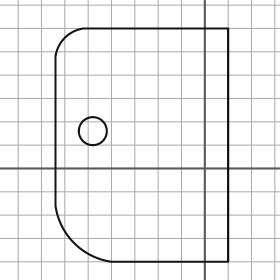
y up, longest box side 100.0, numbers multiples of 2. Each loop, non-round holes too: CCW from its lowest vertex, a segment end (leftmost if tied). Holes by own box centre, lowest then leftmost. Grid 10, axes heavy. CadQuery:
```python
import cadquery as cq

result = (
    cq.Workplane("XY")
    .moveTo(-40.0, -40.0)
    .lineTo(10.0, -40.0)
    .lineTo(10.0, 60.0)
    .lineTo(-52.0, 60.0)
    .threePointArc((-60.0, 56.0), (-64.0, 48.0))
    .lineTo(-64.0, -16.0)
    .threePointArc((-56.0, -32.0), (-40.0, -40.0))
    .close()
    .moveTo(-48.0, 16.0)
    .circle(6.0)
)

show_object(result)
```